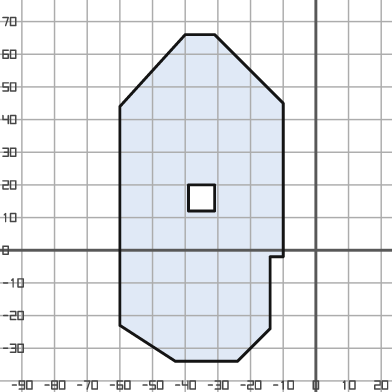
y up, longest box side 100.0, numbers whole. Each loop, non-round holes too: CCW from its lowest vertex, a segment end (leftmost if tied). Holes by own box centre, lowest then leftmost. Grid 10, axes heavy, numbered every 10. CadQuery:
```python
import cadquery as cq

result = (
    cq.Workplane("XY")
    .moveTo(-43.0, -34.0)
    .lineTo(-24.0, -34.0)
    .lineTo(-14.0, -24.0)
    .lineTo(-14.0, -2.0)
    .lineTo(-10.0, -2.0)
    .lineTo(-10.0, 45.0)
    .lineTo(-31.0, 66.0)
    .lineTo(-40.0, 66.0)
    .lineTo(-60.0, 44.0)
    .lineTo(-60.0, -23.0)
    .close()
    .moveTo(-39.0, 12.0)
    .lineTo(-31.0, 12.0)
    .lineTo(-31.0, 20.0)
    .lineTo(-39.0, 20.0)
    .close()
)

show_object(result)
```